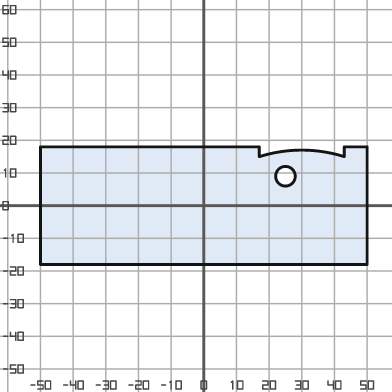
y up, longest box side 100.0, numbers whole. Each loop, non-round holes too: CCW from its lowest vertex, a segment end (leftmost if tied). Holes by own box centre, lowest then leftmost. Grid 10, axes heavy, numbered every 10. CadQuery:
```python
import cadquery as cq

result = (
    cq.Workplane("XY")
    .moveTo(-50.0, -18.0)
    .lineTo(50.0, -18.0)
    .lineTo(50.0, 18.0)
    .lineTo(43.0, 18.0)
    .lineTo(43.0, 15.0)
    .threePointArc((30.0, 17.0), (17.0, 15.0))
    .lineTo(17.0, 18.0)
    .lineTo(-50.0, 18.0)
    .close()
    .moveTo(25.0, 9.0)
    .circle(3.0)
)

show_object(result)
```